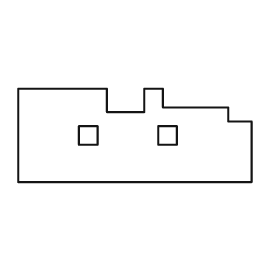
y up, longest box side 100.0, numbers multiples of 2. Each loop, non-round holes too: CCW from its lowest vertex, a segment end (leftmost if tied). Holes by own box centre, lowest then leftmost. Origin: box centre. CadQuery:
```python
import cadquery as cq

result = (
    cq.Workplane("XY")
    .moveTo(-50.0, -20.0)
    .lineTo(50.0, -20.0)
    .lineTo(50.0, 6.0)
    .lineTo(40.0, 6.0)
    .lineTo(40.0, 12.0)
    .lineTo(12.0, 12.0)
    .lineTo(12.0, 20.0)
    .lineTo(4.0, 20.0)
    .lineTo(4.0, 10.0)
    .lineTo(-12.0, 10.0)
    .lineTo(-12.0, 20.0)
    .lineTo(-50.0, 20.0)
    .close()
    .moveTo(-24.0, -4.0)
    .lineTo(-16.0, -4.0)
    .lineTo(-16.0, 4.0)
    .lineTo(-24.0, 4.0)
    .close()
    .moveTo(10.0, -4.0)
    .lineTo(18.0, -4.0)
    .lineTo(18.0, 4.0)
    .lineTo(10.0, 4.0)
    .close()
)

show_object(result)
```